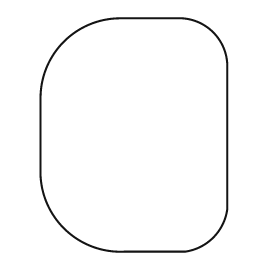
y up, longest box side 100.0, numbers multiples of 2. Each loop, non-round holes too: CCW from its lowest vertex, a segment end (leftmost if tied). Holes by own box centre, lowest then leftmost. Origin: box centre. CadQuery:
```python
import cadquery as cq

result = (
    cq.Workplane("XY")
    .moveTo(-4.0, -50.0)
    .lineTo(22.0, -50.0)
    .threePointArc((34.0, -44.0), (40.0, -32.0))
    .lineTo(40.0, 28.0)
    .threePointArc((34.0, 44.0), (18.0, 50.0))
    .lineTo(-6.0, 50.0)
    .threePointArc((-30.0, 40.0), (-40.0, 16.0))
    .lineTo(-40.0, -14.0)
    .threePointArc((-30.0, -40.0), (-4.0, -50.0))
    .close()
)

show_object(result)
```